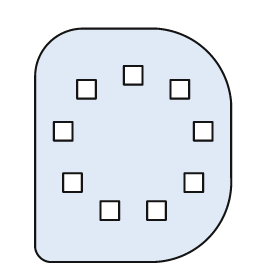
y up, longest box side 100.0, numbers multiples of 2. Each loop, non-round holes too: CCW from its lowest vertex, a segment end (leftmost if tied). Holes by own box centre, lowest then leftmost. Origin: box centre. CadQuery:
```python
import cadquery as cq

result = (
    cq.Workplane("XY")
    .moveTo(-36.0, -50.0)
    .lineTo(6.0, -50.0)
    .threePointArc((32.0, -40.0), (42.0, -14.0))
    .lineTo(42.0, 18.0)
    .threePointArc((32.0, 40.0), (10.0, 50.0))
    .lineTo(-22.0, 50.0)
    .threePointArc((-36.0, 44.0), (-42.0, 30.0))
    .lineTo(-42.0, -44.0)
    .threePointArc((-40.0, -48.0), (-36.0, -50.0))
    .close()
    .moveTo(-14.0, -32.0)
    .lineTo(-6.0, -32.0)
    .lineTo(-6.0, -24.0)
    .lineTo(-14.0, -24.0)
    .close()
    .moveTo(6.0, -32.0)
    .lineTo(14.0, -32.0)
    .lineTo(14.0, -24.0)
    .lineTo(6.0, -24.0)
    .close()
    .moveTo(-30.0, -20.0)
    .lineTo(-22.0, -20.0)
    .lineTo(-22.0, -12.0)
    .lineTo(-30.0, -12.0)
    .close()
    .moveTo(22.0, -20.0)
    .lineTo(30.0, -20.0)
    .lineTo(30.0, -12.0)
    .lineTo(22.0, -12.0)
    .close()
    .moveTo(-34.0, 2.0)
    .lineTo(-26.0, 2.0)
    .lineTo(-26.0, 10.0)
    .lineTo(-34.0, 10.0)
    .close()
    .moveTo(26.0, 2.0)
    .lineTo(34.0, 2.0)
    .lineTo(34.0, 10.0)
    .lineTo(26.0, 10.0)
    .close()
    .moveTo(-24.0, 20.0)
    .lineTo(-16.0, 20.0)
    .lineTo(-16.0, 28.0)
    .lineTo(-24.0, 28.0)
    .close()
    .moveTo(16.0, 20.0)
    .lineTo(24.0, 20.0)
    .lineTo(24.0, 28.0)
    .lineTo(16.0, 28.0)
    .close()
    .moveTo(-4.0, 26.0)
    .lineTo(4.0, 26.0)
    .lineTo(4.0, 34.0)
    .lineTo(-4.0, 34.0)
    .close()
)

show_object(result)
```